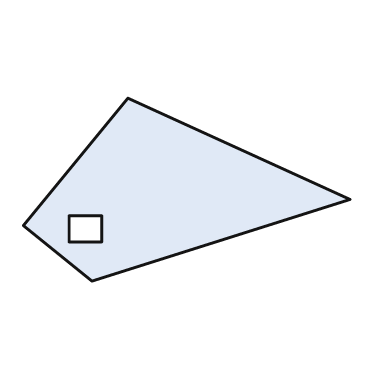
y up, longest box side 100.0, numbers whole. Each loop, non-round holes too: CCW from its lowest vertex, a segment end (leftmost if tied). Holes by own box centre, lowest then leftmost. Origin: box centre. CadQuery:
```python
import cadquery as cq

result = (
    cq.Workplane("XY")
    .moveTo(-29.0, -28.0)
    .lineTo(50.0, -3.0)
    .lineTo(-18.0, 28.0)
    .lineTo(-50.0, -11.0)
    .close()
    .moveTo(-36.0, -16.0)
    .lineTo(-26.0, -16.0)
    .lineTo(-26.0, -8.0)
    .lineTo(-36.0, -8.0)
    .close()
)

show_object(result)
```